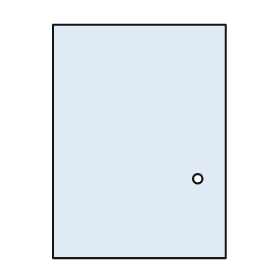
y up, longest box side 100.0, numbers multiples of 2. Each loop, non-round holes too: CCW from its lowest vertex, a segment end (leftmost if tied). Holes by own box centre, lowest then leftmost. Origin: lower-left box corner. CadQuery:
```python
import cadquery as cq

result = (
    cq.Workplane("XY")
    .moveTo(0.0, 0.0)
    .lineTo(74.0, 0.0)
    .lineTo(74.0, 100.0)
    .lineTo(0.0, 100.0)
    .close()
    .moveTo(62.0, 34.0)
    .circle(2.0)
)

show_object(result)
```